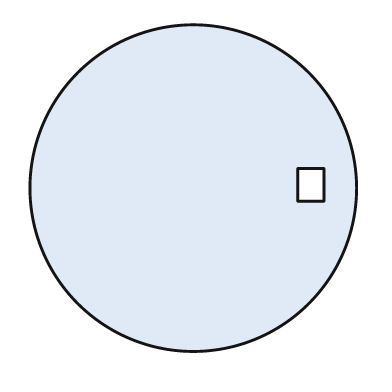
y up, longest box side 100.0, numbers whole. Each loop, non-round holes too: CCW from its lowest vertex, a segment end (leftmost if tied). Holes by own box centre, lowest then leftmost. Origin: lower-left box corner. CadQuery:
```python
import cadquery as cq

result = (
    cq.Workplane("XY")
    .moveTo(50.0, 50.0)
    .circle(50.0)
    .moveTo(82.0, 46.0)
    .lineTo(90.0, 46.0)
    .lineTo(90.0, 56.0)
    .lineTo(82.0, 56.0)
    .close()
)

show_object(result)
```